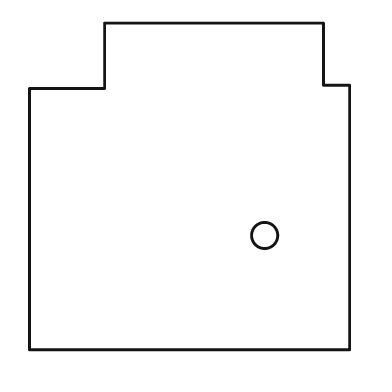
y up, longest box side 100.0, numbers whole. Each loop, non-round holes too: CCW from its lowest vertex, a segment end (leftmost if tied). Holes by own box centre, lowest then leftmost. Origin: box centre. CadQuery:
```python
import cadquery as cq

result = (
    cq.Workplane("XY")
    .moveTo(-49.0, -50.0)
    .lineTo(49.0, -50.0)
    .lineTo(49.0, 31.0)
    .lineTo(41.0, 31.0)
    .lineTo(41.0, 50.0)
    .lineTo(-26.0, 50.0)
    .lineTo(-26.0, 30.0)
    .lineTo(-49.0, 30.0)
    .close()
    .moveTo(23.0, -15.0)
    .circle(4.0)
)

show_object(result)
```